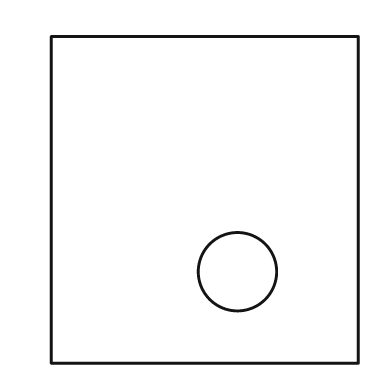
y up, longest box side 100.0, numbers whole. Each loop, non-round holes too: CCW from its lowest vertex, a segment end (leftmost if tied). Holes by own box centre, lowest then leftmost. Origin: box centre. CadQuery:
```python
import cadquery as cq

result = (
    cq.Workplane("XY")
    .moveTo(-47.0, -50.0)
    .lineTo(47.0, -50.0)
    .lineTo(47.0, 50.0)
    .lineTo(-47.0, 50.0)
    .close()
    .moveTo(10.0, -22.0)
    .circle(12.0)
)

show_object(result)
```